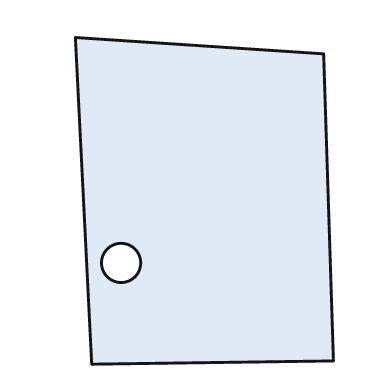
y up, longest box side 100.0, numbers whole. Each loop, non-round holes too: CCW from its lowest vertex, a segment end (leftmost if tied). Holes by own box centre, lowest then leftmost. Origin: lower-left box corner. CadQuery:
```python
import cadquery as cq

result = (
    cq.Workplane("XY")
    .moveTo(5.0, 0.0)
    .lineTo(79.0, 1.0)
    .lineTo(76.0, 95.0)
    .lineTo(0.0, 100.0)
    .close()
    .moveTo(14.0, 31.0)
    .circle(6.0)
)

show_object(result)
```